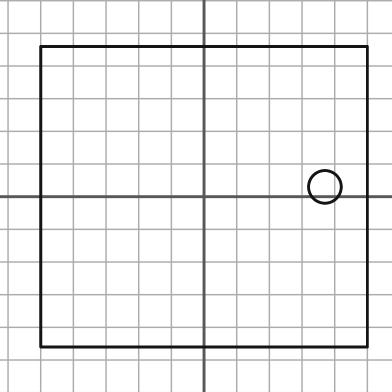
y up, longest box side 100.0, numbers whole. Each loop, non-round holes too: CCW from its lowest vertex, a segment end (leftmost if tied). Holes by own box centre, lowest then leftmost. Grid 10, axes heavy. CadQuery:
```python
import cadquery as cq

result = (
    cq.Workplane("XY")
    .moveTo(-50.0, -46.0)
    .lineTo(50.0, -46.0)
    .lineTo(50.0, 46.0)
    .lineTo(-50.0, 46.0)
    .close()
    .moveTo(37.0, 3.0)
    .circle(5.0)
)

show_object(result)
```